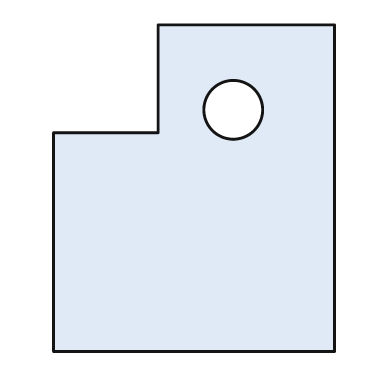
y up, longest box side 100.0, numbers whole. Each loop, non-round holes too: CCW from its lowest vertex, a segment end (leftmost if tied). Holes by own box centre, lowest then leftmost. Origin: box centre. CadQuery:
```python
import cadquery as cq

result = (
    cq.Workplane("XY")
    .moveTo(-43.0, -50.0)
    .lineTo(43.0, -50.0)
    .lineTo(43.0, 50.0)
    .lineTo(-11.0, 50.0)
    .lineTo(-11.0, 17.0)
    .lineTo(-43.0, 17.0)
    .close()
    .moveTo(12.0, 24.0)
    .circle(9.0)
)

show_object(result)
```